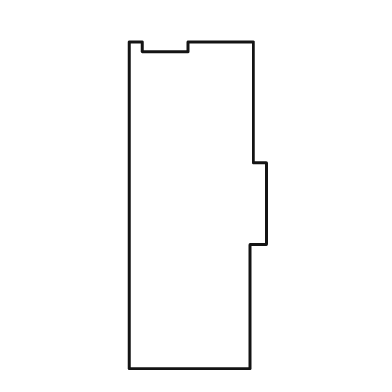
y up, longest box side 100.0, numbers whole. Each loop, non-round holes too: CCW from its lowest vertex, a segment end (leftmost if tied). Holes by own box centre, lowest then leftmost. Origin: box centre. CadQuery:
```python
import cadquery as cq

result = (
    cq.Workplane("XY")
    .moveTo(-21.0, -50.0)
    .lineTo(16.0, -50.0)
    .lineTo(16.0, -12.0)
    .lineTo(21.0, -12.0)
    .lineTo(21.0, 13.0)
    .lineTo(17.0, 13.0)
    .lineTo(17.0, 50.0)
    .lineTo(-3.0, 50.0)
    .lineTo(-3.0, 47.0)
    .lineTo(-17.0, 47.0)
    .lineTo(-17.0, 50.0)
    .lineTo(-21.0, 50.0)
    .close()
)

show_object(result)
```